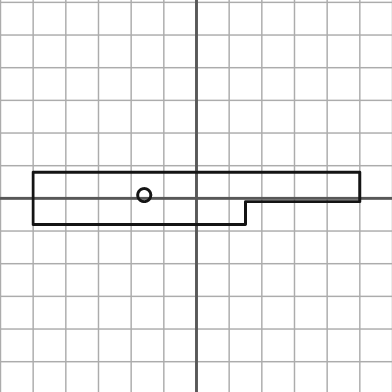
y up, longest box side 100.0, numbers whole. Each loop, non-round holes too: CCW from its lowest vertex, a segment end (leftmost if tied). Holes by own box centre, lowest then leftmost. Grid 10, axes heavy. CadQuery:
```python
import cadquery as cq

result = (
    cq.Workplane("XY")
    .moveTo(-50.0, -8.0)
    .lineTo(15.0, -8.0)
    .lineTo(15.0, -1.0)
    .lineTo(50.0, -1.0)
    .lineTo(50.0, 8.0)
    .lineTo(-50.0, 8.0)
    .close()
    .moveTo(-16.0, 1.0)
    .circle(2.0)
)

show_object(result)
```